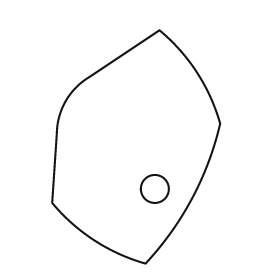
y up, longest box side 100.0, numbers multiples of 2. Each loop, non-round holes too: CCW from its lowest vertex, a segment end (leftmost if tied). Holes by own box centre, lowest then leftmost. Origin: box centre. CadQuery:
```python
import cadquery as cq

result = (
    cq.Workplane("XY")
    .moveTo(4.0, -50.0)
    .threePointArc((24.0, -22.0), (36.0, 10.0))
    .threePointArc((26.0, 32.0), (10.0, 50.0))
    .lineTo(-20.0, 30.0)
    .threePointArc((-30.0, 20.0), (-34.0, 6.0))
    .lineTo(-36.0, -24.0)
    .threePointArc((-18.0, -40.0), (4.0, -50.0))
    .close()
    .moveTo(8.0, -18.0)
    .circle(6.0)
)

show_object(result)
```